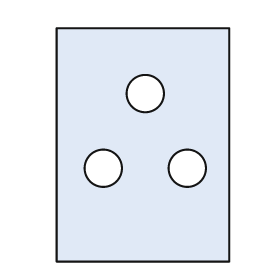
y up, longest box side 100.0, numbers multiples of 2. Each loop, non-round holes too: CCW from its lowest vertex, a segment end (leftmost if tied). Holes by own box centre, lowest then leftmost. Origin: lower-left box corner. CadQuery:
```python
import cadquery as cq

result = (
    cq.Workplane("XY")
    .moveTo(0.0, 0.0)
    .lineTo(74.0, 0.0)
    .lineTo(74.0, 100.0)
    .lineTo(0.0, 100.0)
    .close()
    .moveTo(20.0, 40.0)
    .circle(8.0)
    .moveTo(56.0, 40.0)
    .circle(8.0)
    .moveTo(38.0, 72.0)
    .circle(8.0)
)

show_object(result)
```